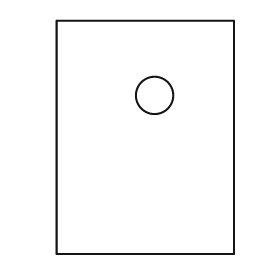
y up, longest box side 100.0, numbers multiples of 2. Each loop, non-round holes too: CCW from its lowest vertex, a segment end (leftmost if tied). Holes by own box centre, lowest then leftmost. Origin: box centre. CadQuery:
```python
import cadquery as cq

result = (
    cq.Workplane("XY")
    .moveTo(-38.0, -50.0)
    .lineTo(38.0, -50.0)
    .lineTo(38.0, 50.0)
    .lineTo(-38.0, 50.0)
    .close()
    .moveTo(4.0, 18.0)
    .circle(8.0)
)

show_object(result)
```